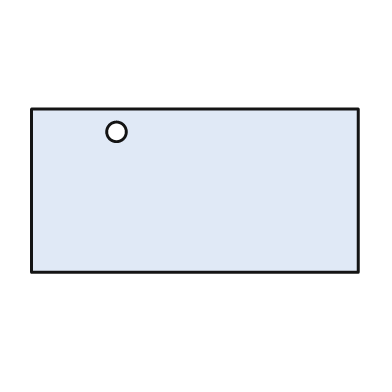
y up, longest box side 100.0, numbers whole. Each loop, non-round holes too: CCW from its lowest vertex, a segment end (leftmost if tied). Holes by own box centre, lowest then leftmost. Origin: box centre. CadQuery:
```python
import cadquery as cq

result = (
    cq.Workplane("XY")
    .moveTo(-50.0, -25.0)
    .lineTo(50.0, -25.0)
    .lineTo(50.0, 25.0)
    .lineTo(-50.0, 25.0)
    .close()
    .moveTo(-24.0, 18.0)
    .circle(3.0)
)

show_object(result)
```